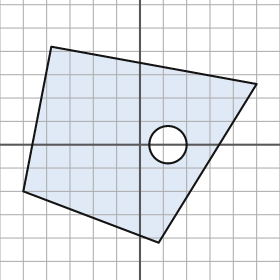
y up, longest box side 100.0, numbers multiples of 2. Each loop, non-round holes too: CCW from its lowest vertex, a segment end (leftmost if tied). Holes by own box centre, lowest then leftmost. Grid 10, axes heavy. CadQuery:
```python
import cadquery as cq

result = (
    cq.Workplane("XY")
    .moveTo(8.0, -42.0)
    .lineTo(50.0, 26.0)
    .lineTo(-38.0, 42.0)
    .lineTo(-50.0, -20.0)
    .close()
    .moveTo(12.0, 0.0)
    .circle(8.0)
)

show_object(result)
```